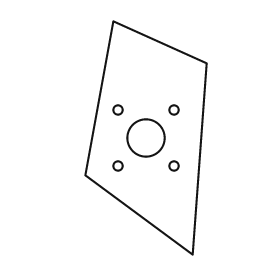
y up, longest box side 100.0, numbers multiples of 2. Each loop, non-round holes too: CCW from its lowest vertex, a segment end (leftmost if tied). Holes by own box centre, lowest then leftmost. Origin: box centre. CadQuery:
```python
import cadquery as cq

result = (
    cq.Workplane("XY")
    .moveTo(20.0, -50.0)
    .lineTo(26.0, 32.0)
    .lineTo(-14.0, 50.0)
    .lineTo(-26.0, -16.0)
    .close()
    .moveTo(-12.0, -12.0)
    .circle(2.0)
    .moveTo(12.0, -12.0)
    .circle(2.0)
    .moveTo(0.0, 0.0)
    .circle(8.0)
    .moveTo(-12.0, 12.0)
    .circle(2.0)
    .moveTo(12.0, 12.0)
    .circle(2.0)
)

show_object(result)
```